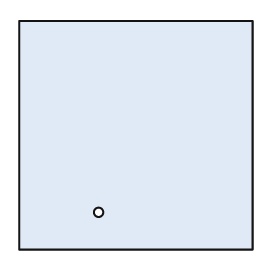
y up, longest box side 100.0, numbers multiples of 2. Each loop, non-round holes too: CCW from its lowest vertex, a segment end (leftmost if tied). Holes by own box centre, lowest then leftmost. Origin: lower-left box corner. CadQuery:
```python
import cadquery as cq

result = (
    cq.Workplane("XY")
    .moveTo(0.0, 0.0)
    .lineTo(100.0, 0.0)
    .lineTo(100.0, 98.0)
    .lineTo(0.0, 98.0)
    .close()
    .moveTo(34.0, 16.0)
    .circle(2.0)
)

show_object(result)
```